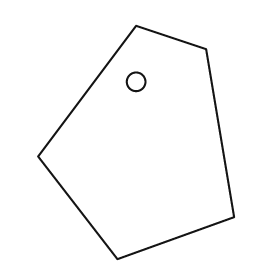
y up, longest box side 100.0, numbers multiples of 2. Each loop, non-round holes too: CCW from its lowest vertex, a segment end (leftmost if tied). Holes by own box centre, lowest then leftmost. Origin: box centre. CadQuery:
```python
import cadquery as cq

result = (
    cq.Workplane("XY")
    .moveTo(-8.0, -50.0)
    .lineTo(42.0, -32.0)
    .lineTo(30.0, 40.0)
    .lineTo(0.0, 50.0)
    .lineTo(-42.0, -6.0)
    .close()
    .moveTo(0.0, 26.0)
    .circle(4.0)
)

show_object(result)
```